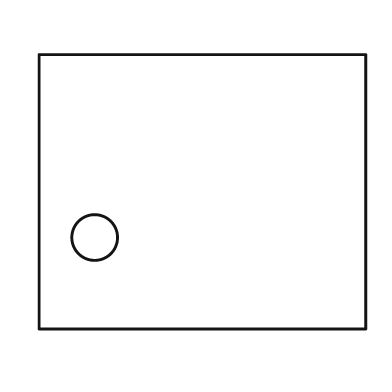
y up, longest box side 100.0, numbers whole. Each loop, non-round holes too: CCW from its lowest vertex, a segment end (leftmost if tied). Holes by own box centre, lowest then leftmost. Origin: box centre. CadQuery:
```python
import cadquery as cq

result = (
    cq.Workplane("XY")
    .moveTo(-50.0, -42.0)
    .lineTo(50.0, -42.0)
    .lineTo(50.0, 42.0)
    .lineTo(-50.0, 42.0)
    .close()
    .moveTo(-33.0, -14.0)
    .circle(7.0)
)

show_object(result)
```